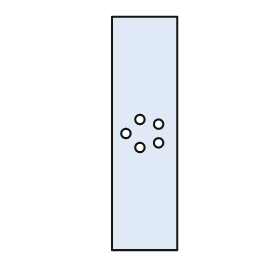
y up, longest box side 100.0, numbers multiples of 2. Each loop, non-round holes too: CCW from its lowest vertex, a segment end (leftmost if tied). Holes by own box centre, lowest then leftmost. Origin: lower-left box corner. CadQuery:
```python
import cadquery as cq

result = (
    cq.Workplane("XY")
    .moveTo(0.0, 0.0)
    .lineTo(28.0, 0.0)
    .lineTo(28.0, 100.0)
    .lineTo(0.0, 100.0)
    .close()
    .moveTo(12.0, 44.0)
    .circle(2.0)
    .moveTo(20.0, 46.0)
    .circle(2.0)
    .moveTo(6.0, 50.0)
    .circle(2.0)
    .moveTo(20.0, 54.0)
    .circle(2.0)
    .moveTo(12.0, 56.0)
    .circle(2.0)
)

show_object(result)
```